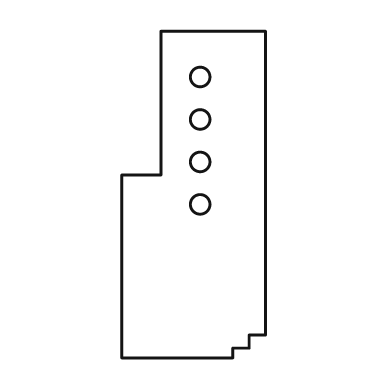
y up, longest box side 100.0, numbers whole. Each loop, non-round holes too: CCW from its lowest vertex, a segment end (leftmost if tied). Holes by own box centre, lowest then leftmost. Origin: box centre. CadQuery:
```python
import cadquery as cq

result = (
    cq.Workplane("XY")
    .moveTo(-22.0, -50.0)
    .lineTo(12.0, -50.0)
    .lineTo(12.0, -47.0)
    .lineTo(17.0, -47.0)
    .lineTo(17.0, -43.0)
    .lineTo(22.0, -43.0)
    .lineTo(22.0, 50.0)
    .lineTo(-10.0, 50.0)
    .lineTo(-10.0, 6.0)
    .lineTo(-22.0, 6.0)
    .close()
    .moveTo(2.0, -3.0)
    .circle(3.0)
    .moveTo(2.0, 10.0)
    .circle(3.0)
    .moveTo(2.0, 23.0)
    .circle(3.0)
    .moveTo(2.0, 36.0)
    .circle(3.0)
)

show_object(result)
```